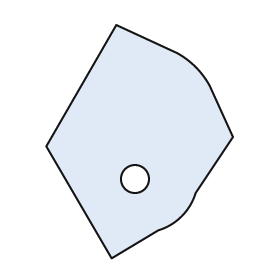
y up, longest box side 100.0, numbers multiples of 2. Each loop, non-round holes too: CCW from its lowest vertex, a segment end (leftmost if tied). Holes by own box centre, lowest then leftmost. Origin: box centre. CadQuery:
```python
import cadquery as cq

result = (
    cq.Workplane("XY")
    .moveTo(-12.0, -50.0)
    .lineTo(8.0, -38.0)
    .threePointArc((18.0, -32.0), (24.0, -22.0))
    .lineTo(40.0, 2.0)
    .lineTo(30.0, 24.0)
    .threePointArc((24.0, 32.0), (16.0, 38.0))
    .lineTo(-10.0, 50.0)
    .lineTo(-40.0, -2.0)
    .close()
    .moveTo(-2.0, -16.0)
    .circle(6.0)
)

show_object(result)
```